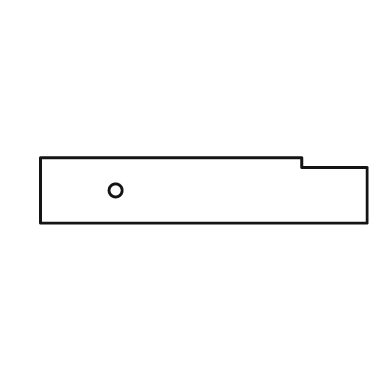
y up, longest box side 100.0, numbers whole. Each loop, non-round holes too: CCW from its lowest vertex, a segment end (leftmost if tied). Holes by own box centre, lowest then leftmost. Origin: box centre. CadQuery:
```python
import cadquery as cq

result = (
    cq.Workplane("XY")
    .moveTo(-50.0, -10.0)
    .lineTo(50.0, -10.0)
    .lineTo(50.0, 7.0)
    .lineTo(30.0, 7.0)
    .lineTo(30.0, 10.0)
    .lineTo(-50.0, 10.0)
    .close()
    .moveTo(-27.0, 0.0)
    .circle(2.0)
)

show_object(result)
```